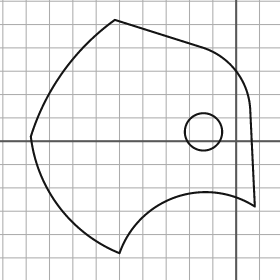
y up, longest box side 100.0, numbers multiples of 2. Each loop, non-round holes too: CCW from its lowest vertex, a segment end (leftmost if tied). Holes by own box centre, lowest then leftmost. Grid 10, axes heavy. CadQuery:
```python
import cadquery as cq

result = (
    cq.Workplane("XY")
    .moveTo(-50.0, -48.0)
    .threePointArc((-26.0, -24.0), (8.0, -28.0))
    .lineTo(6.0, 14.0)
    .threePointArc((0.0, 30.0), (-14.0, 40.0))
    .lineTo(-52.0, 52.0)
    .threePointArc((-74.0, 30.0), (-88.0, 2.0))
    .threePointArc((-76.0, -28.0), (-50.0, -48.0))
    .close()
    .moveTo(-14.0, 4.0)
    .circle(8.0)
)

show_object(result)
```